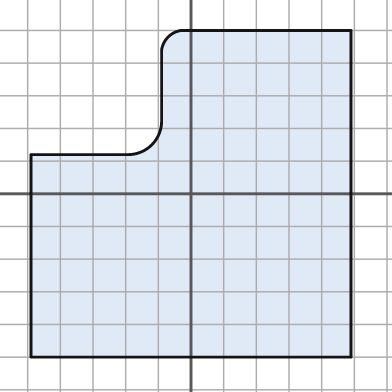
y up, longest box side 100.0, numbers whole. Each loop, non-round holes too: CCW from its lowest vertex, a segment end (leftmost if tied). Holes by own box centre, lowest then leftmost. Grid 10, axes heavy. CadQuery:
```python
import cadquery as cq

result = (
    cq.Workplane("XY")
    .moveTo(-49.0, -50.0)
    .lineTo(49.0, -50.0)
    .lineTo(49.0, 50.0)
    .lineTo(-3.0, 50.0)
    .threePointArc((-7.0, 48.0), (-9.0, 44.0))
    .lineTo(-9.0, 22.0)
    .threePointArc((-12.0, 15.0), (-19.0, 12.0))
    .lineTo(-49.0, 12.0)
    .close()
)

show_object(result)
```